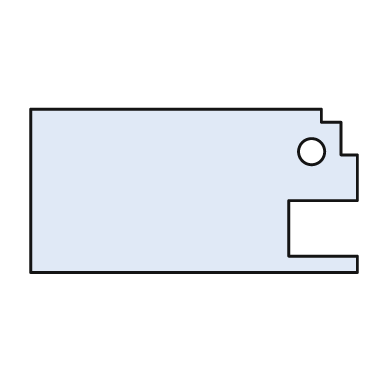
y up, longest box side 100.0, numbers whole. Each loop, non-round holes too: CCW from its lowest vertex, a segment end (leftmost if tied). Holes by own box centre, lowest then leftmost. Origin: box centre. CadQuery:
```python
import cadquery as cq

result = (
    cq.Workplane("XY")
    .moveTo(-50.0, -25.0)
    .lineTo(50.0, -25.0)
    .lineTo(50.0, -20.0)
    .lineTo(29.0, -20.0)
    .lineTo(29.0, -3.0)
    .lineTo(50.0, -3.0)
    .lineTo(50.0, 11.0)
    .lineTo(45.0, 11.0)
    .lineTo(45.0, 21.0)
    .lineTo(39.0, 21.0)
    .lineTo(39.0, 25.0)
    .lineTo(-50.0, 25.0)
    .close()
    .moveTo(36.0, 12.0)
    .circle(4.0)
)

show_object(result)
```